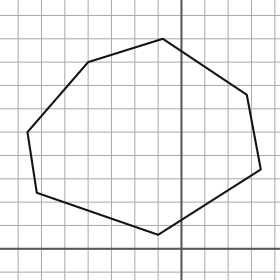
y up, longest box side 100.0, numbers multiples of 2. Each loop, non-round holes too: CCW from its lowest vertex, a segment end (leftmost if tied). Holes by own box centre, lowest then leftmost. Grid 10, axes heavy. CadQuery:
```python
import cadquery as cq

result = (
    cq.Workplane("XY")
    .moveTo(-10.0, 6.0)
    .lineTo(34.0, 34.0)
    .lineTo(28.0, 66.0)
    .lineTo(-8.0, 90.0)
    .lineTo(-40.0, 80.0)
    .lineTo(-66.0, 50.0)
    .lineTo(-62.0, 24.0)
    .close()
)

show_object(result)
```